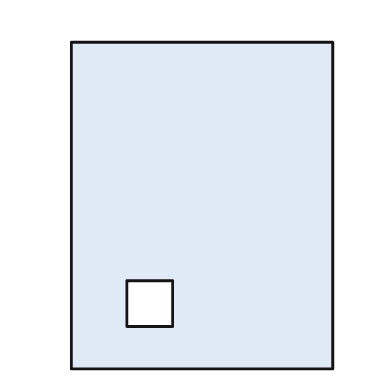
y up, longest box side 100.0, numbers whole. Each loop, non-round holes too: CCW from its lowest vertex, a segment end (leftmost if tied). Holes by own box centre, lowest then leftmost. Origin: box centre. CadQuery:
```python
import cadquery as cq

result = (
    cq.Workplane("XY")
    .moveTo(-40.0, -50.0)
    .lineTo(40.0, -50.0)
    .lineTo(40.0, 50.0)
    .lineTo(-40.0, 50.0)
    .close()
    .moveTo(-23.0, -37.0)
    .lineTo(-9.0, -37.0)
    .lineTo(-9.0, -23.0)
    .lineTo(-23.0, -23.0)
    .close()
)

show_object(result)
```